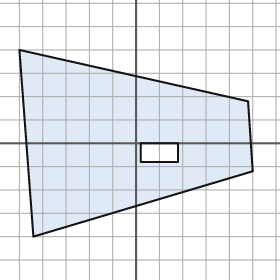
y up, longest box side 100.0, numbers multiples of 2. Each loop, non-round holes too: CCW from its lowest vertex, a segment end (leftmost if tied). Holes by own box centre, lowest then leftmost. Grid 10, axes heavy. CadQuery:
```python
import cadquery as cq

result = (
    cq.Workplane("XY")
    .moveTo(-44.0, -40.0)
    .lineTo(50.0, -12.0)
    .lineTo(48.0, 18.0)
    .lineTo(-50.0, 40.0)
    .close()
    .moveTo(2.0, -8.0)
    .lineTo(18.0, -8.0)
    .lineTo(18.0, 0.0)
    .lineTo(2.0, 0.0)
    .close()
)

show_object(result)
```